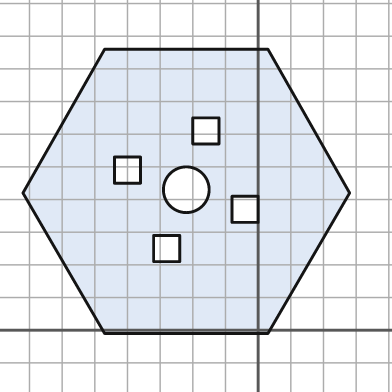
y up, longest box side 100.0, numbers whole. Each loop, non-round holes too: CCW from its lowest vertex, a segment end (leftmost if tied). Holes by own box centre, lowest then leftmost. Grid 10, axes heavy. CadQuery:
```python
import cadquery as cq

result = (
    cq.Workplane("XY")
    .moveTo(-47.0, -1.0)
    .lineTo(3.0, -1.0)
    .lineTo(28.0, 42.0)
    .lineTo(3.0, 86.0)
    .lineTo(-47.0, 86.0)
    .lineTo(-72.0, 42.0)
    .close()
    .moveTo(-32.0, 21.0)
    .lineTo(-24.0, 21.0)
    .lineTo(-24.0, 29.0)
    .lineTo(-32.0, 29.0)
    .close()
    .moveTo(-8.0, 33.0)
    .lineTo(0.0, 33.0)
    .lineTo(0.0, 41.0)
    .lineTo(-8.0, 41.0)
    .close()
    .moveTo(-22.0, 43.0)
    .circle(7.0)
    .moveTo(-44.0, 45.0)
    .lineTo(-36.0, 45.0)
    .lineTo(-36.0, 53.0)
    .lineTo(-44.0, 53.0)
    .close()
    .moveTo(-20.0, 57.0)
    .lineTo(-12.0, 57.0)
    .lineTo(-12.0, 65.0)
    .lineTo(-20.0, 65.0)
    .close()
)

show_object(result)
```